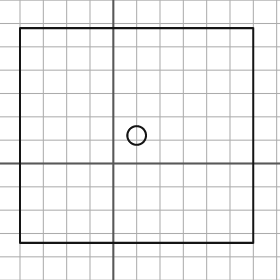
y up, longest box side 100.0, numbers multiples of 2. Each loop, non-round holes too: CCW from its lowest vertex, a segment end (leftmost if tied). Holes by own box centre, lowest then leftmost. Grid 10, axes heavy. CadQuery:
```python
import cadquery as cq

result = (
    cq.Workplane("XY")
    .moveTo(-40.0, -34.0)
    .lineTo(60.0, -34.0)
    .lineTo(60.0, 58.0)
    .lineTo(-40.0, 58.0)
    .close()
    .moveTo(10.0, 12.0)
    .circle(4.0)
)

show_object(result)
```